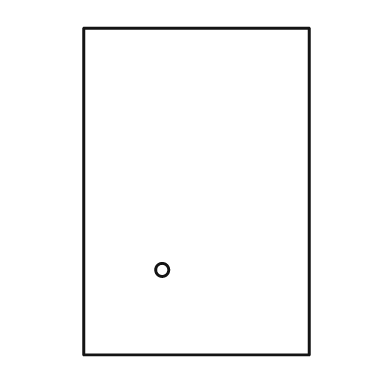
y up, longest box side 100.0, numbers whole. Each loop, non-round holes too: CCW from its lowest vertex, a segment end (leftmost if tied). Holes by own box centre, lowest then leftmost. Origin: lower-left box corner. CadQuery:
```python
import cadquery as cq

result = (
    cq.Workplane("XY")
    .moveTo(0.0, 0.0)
    .lineTo(69.0, 0.0)
    .lineTo(69.0, 100.0)
    .lineTo(0.0, 100.0)
    .close()
    .moveTo(24.0, 26.0)
    .circle(2.0)
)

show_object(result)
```